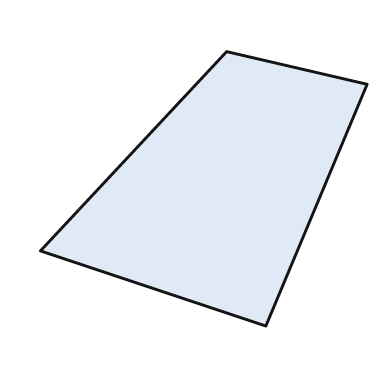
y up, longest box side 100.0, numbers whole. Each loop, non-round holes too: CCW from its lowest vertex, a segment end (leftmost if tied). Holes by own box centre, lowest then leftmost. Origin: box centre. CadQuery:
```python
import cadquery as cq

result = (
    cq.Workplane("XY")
    .moveTo(19.0, -42.0)
    .lineTo(50.0, 32.0)
    .lineTo(7.0, 42.0)
    .lineTo(-50.0, -19.0)
    .close()
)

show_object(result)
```